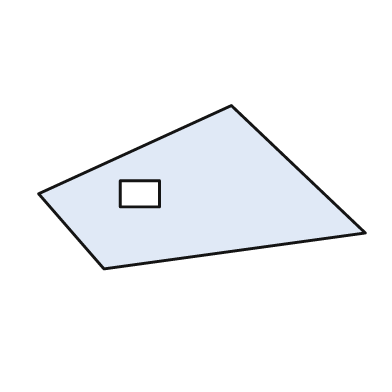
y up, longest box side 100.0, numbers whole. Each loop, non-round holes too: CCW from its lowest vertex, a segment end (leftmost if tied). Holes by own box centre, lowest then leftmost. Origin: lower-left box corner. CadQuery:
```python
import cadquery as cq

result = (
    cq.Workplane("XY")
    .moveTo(20.0, 0.0)
    .lineTo(100.0, 11.0)
    .lineTo(59.0, 50.0)
    .lineTo(0.0, 23.0)
    .close()
    .moveTo(25.0, 19.0)
    .lineTo(37.0, 19.0)
    .lineTo(37.0, 27.0)
    .lineTo(25.0, 27.0)
    .close()
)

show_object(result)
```